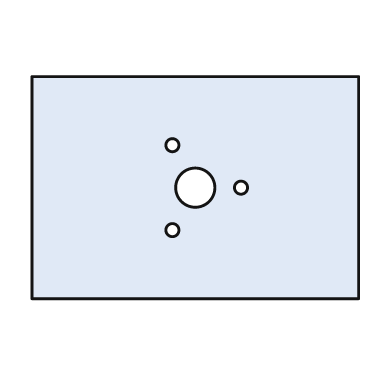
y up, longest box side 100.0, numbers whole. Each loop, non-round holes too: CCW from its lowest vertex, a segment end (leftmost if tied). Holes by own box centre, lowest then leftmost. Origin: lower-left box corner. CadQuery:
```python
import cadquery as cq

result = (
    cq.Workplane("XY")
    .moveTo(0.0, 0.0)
    .lineTo(100.0, 0.0)
    .lineTo(100.0, 68.0)
    .lineTo(0.0, 68.0)
    .close()
    .moveTo(43.0, 21.0)
    .circle(2.0)
    .moveTo(50.0, 34.0)
    .circle(6.0)
    .moveTo(64.0, 34.0)
    .circle(2.0)
    .moveTo(43.0, 47.0)
    .circle(2.0)
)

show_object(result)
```